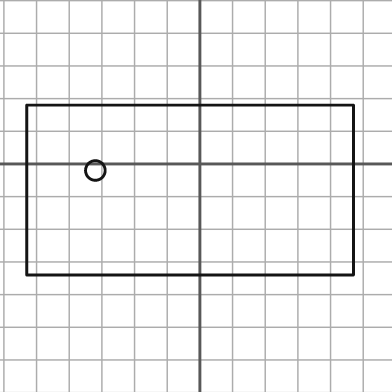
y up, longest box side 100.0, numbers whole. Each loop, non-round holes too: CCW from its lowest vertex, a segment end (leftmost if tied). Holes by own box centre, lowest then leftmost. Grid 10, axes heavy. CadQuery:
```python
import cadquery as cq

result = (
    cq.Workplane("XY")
    .moveTo(-53.0, -34.0)
    .lineTo(47.0, -34.0)
    .lineTo(47.0, 18.0)
    .lineTo(-53.0, 18.0)
    .close()
    .moveTo(-32.0, -2.0)
    .circle(3.0)
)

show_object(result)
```